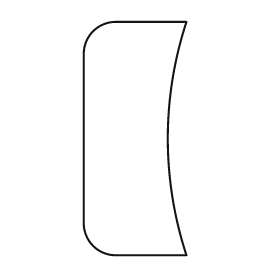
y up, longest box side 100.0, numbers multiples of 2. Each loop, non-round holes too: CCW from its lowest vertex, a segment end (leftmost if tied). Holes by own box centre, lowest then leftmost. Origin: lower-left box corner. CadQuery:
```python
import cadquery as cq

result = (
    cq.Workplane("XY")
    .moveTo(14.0, 0.0)
    .lineTo(44.0, 0.0)
    .threePointArc((36.0, 50.0), (44.0, 100.0))
    .lineTo(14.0, 100.0)
    .threePointArc((4.0, 96.0), (0.0, 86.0))
    .lineTo(0.0, 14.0)
    .threePointArc((4.0, 4.0), (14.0, 0.0))
    .close()
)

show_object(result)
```